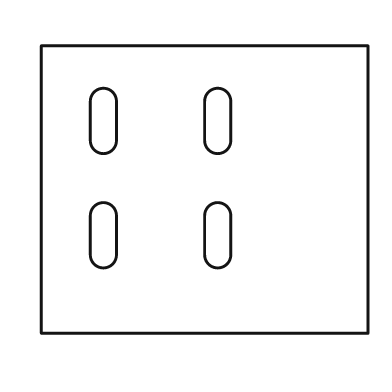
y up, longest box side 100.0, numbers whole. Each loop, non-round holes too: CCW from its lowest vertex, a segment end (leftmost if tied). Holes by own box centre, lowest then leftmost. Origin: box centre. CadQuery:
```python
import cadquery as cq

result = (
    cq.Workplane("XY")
    .moveTo(-50.0, -44.0)
    .lineTo(50.0, -44.0)
    .lineTo(50.0, 44.0)
    .lineTo(-50.0, 44.0)
    .close()
    .moveTo(-35.0, -20.0)
    .threePointArc((-31.0, -24.0), (-27.0, -20.0))
    .lineTo(-27.0, -8.0)
    .threePointArc((-31.0, -4.0), (-35.0, -8.0))
    .close()
    .moveTo(0.0, -20.0)
    .threePointArc((4.0, -24.0), (8.0, -20.0))
    .lineTo(8.0, -8.0)
    .threePointArc((4.0, -4.0), (0.0, -8.0))
    .close()
    .moveTo(-35.0, 15.0)
    .threePointArc((-31.0, 11.0), (-27.0, 15.0))
    .lineTo(-27.0, 27.0)
    .threePointArc((-31.0, 31.0), (-35.0, 27.0))
    .close()
    .moveTo(0.0, 15.0)
    .threePointArc((4.0, 11.0), (8.0, 15.0))
    .lineTo(8.0, 27.0)
    .threePointArc((4.0, 31.0), (0.0, 27.0))
    .close()
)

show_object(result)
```